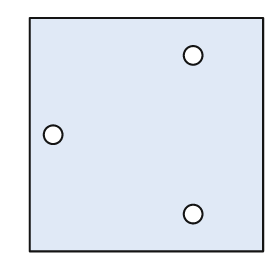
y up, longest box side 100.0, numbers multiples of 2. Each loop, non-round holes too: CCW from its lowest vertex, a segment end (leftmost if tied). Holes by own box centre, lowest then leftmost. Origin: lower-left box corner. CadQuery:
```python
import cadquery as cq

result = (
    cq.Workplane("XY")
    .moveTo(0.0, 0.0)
    .lineTo(100.0, 0.0)
    .lineTo(100.0, 100.0)
    .lineTo(0.0, 100.0)
    .close()
    .moveTo(70.0, 16.0)
    .circle(4.0)
    .moveTo(10.0, 50.0)
    .circle(4.0)
    .moveTo(70.0, 84.0)
    .circle(4.0)
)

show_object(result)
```